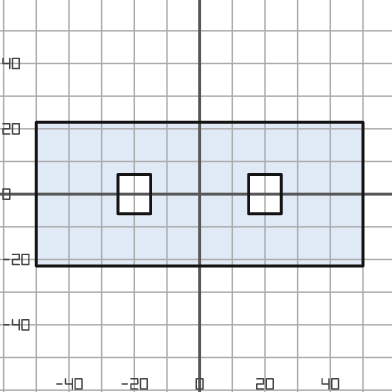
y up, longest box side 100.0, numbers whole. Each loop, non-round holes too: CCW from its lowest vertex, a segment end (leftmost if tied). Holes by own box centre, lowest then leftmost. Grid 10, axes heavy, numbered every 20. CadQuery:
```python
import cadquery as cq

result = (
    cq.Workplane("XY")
    .moveTo(-50.0, -22.0)
    .lineTo(50.0, -22.0)
    .lineTo(50.0, 22.0)
    .lineTo(-50.0, 22.0)
    .close()
    .moveTo(-25.0, -6.0)
    .lineTo(-15.0, -6.0)
    .lineTo(-15.0, 6.0)
    .lineTo(-25.0, 6.0)
    .close()
    .moveTo(15.0, -6.0)
    .lineTo(25.0, -6.0)
    .lineTo(25.0, 6.0)
    .lineTo(15.0, 6.0)
    .close()
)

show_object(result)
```